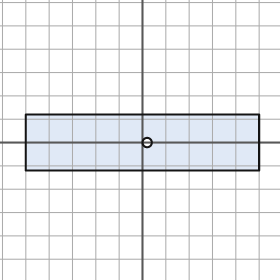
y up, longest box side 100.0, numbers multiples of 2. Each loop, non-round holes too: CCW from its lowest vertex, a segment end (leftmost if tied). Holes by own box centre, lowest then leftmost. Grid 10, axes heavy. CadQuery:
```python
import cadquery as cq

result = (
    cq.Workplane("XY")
    .moveTo(-50.0, -12.0)
    .lineTo(50.0, -12.0)
    .lineTo(50.0, 12.0)
    .lineTo(-50.0, 12.0)
    .close()
    .moveTo(2.0, 0.0)
    .circle(2.0)
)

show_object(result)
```